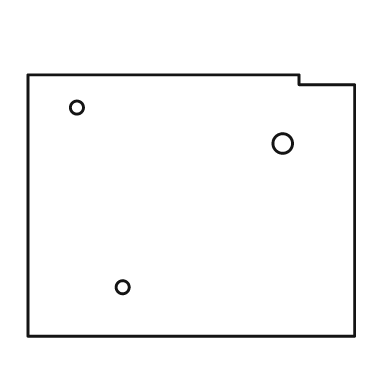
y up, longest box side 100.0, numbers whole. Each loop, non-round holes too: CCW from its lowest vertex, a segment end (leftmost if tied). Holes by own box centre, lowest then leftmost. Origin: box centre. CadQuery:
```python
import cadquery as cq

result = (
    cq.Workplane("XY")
    .moveTo(-50.0, -40.0)
    .lineTo(50.0, -40.0)
    .lineTo(50.0, 37.0)
    .lineTo(33.0, 37.0)
    .lineTo(33.0, 40.0)
    .lineTo(-50.0, 40.0)
    .close()
    .moveTo(-21.0, -25.0)
    .circle(2.0)
    .moveTo(28.0, 19.0)
    .circle(3.0)
    .moveTo(-35.0, 30.0)
    .circle(2.0)
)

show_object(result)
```